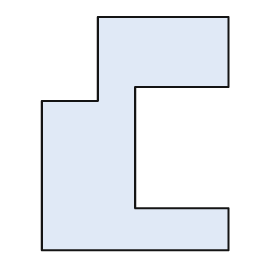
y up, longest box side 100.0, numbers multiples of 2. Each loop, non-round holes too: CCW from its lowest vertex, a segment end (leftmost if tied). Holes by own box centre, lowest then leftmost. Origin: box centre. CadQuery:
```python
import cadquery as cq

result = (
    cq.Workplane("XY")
    .moveTo(-40.0, -50.0)
    .lineTo(40.0, -50.0)
    .lineTo(40.0, -32.0)
    .lineTo(0.0, -32.0)
    .lineTo(0.0, 20.0)
    .lineTo(40.0, 20.0)
    .lineTo(40.0, 50.0)
    .lineTo(-16.0, 50.0)
    .lineTo(-16.0, 14.0)
    .lineTo(-40.0, 14.0)
    .close()
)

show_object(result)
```